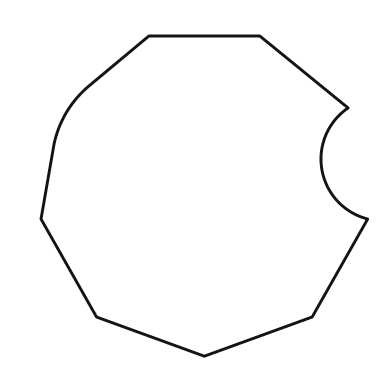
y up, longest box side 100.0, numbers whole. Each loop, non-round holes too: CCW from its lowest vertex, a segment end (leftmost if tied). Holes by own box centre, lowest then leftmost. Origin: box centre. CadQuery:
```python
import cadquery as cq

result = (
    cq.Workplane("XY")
    .moveTo(0.0, -49.0)
    .lineTo(33.0, -37.0)
    .lineTo(50.0, -7.0)
    .threePointArc((36.0, 8.0), (44.0, 27.0))
    .lineTo(17.0, 49.0)
    .lineTo(-17.0, 49.0)
    .lineTo(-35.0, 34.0)
    .threePointArc((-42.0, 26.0), (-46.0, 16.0))
    .lineTo(-50.0, -7.0)
    .lineTo(-33.0, -37.0)
    .close()
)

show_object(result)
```